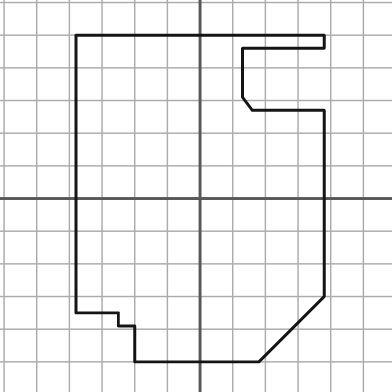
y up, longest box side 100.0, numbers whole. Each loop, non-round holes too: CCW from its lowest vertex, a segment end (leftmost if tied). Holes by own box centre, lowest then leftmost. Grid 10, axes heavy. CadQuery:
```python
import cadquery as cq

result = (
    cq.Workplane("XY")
    .moveTo(-20.0, -50.0)
    .lineTo(18.0, -50.0)
    .lineTo(38.0, -30.0)
    .lineTo(38.0, 27.0)
    .lineTo(16.0, 27.0)
    .lineTo(13.0, 31.0)
    .lineTo(13.0, 46.0)
    .lineTo(38.0, 46.0)
    .lineTo(38.0, 50.0)
    .lineTo(-38.0, 50.0)
    .lineTo(-38.0, -35.0)
    .lineTo(-25.0, -35.0)
    .lineTo(-25.0, -39.0)
    .lineTo(-20.0, -39.0)
    .close()
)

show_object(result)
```